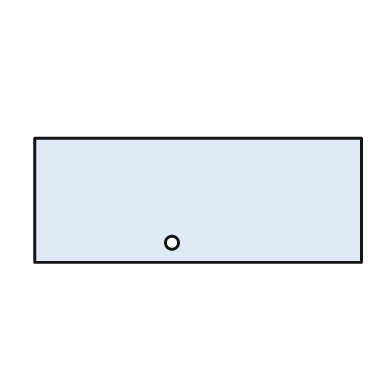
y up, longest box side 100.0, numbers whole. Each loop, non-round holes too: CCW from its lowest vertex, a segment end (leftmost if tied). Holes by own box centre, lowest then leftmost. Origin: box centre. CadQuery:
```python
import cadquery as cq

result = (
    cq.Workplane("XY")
    .moveTo(-50.0, -19.0)
    .lineTo(50.0, -19.0)
    .lineTo(50.0, 19.0)
    .lineTo(-50.0, 19.0)
    .close()
    .moveTo(-8.0, -13.0)
    .circle(2.0)
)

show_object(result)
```